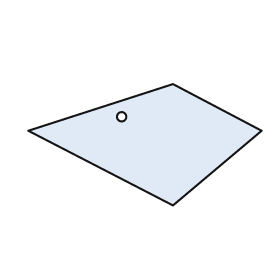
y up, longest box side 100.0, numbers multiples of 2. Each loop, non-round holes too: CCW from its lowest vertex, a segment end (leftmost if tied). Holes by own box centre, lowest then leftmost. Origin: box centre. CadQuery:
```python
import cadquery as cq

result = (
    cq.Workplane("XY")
    .moveTo(12.0, -26.0)
    .lineTo(50.0, 6.0)
    .lineTo(12.0, 26.0)
    .lineTo(-50.0, 6.0)
    .close()
    .moveTo(-10.0, 12.0)
    .circle(2.0)
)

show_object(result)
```